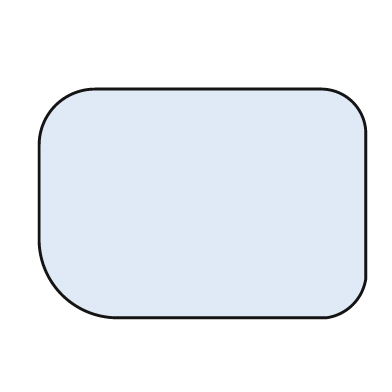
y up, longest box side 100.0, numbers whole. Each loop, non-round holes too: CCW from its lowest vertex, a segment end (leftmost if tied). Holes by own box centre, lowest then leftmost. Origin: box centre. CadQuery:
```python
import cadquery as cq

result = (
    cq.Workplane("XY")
    .moveTo(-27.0, -35.0)
    .lineTo(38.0, -35.0)
    .threePointArc((46.0, -31.0), (50.0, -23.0))
    .lineTo(50.0, 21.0)
    .threePointArc((46.0, 31.0), (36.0, 35.0))
    .lineTo(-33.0, 35.0)
    .threePointArc((-45.0, 30.0), (-50.0, 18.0))
    .lineTo(-50.0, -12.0)
    .threePointArc((-43.0, -28.0), (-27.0, -35.0))
    .close()
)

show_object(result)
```